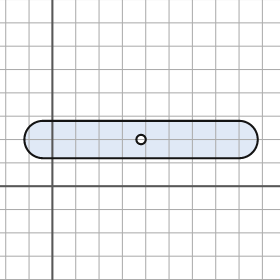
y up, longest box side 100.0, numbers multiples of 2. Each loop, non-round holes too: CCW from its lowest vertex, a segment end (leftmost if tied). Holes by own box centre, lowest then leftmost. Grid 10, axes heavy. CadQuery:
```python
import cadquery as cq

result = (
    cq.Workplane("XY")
    .moveTo(-4.0, 12.0)
    .lineTo(80.0, 12.0)
    .threePointArc((88.0, 20.0), (80.0, 28.0))
    .lineTo(-4.0, 28.0)
    .threePointArc((-12.0, 20.0), (-4.0, 12.0))
    .close()
    .moveTo(38.0, 20.0)
    .circle(2.0)
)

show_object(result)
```